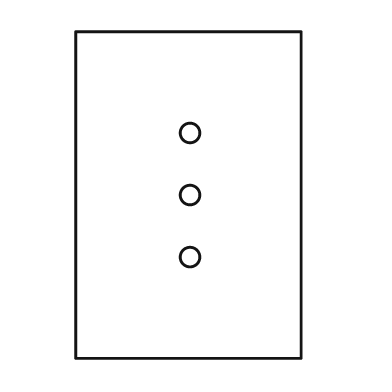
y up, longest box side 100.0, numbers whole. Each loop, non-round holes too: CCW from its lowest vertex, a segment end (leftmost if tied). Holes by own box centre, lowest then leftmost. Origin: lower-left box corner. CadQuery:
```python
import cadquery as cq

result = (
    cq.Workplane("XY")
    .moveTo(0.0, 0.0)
    .lineTo(69.0, 0.0)
    .lineTo(69.0, 100.0)
    .lineTo(0.0, 100.0)
    .close()
    .moveTo(35.0, 31.0)
    .circle(3.0)
    .moveTo(35.0, 50.0)
    .circle(3.0)
    .moveTo(35.0, 69.0)
    .circle(3.0)
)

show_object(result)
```